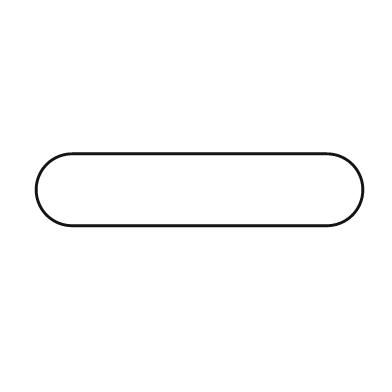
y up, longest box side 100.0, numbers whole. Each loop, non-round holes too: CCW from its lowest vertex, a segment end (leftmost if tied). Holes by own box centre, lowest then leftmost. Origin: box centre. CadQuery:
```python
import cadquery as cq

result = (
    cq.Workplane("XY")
    .moveTo(-39.0, -11.0)
    .lineTo(39.0, -11.0)
    .threePointArc((50.0, 0.0), (39.0, 11.0))
    .lineTo(-39.0, 11.0)
    .threePointArc((-50.0, 0.0), (-39.0, -11.0))
    .close()
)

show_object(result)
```